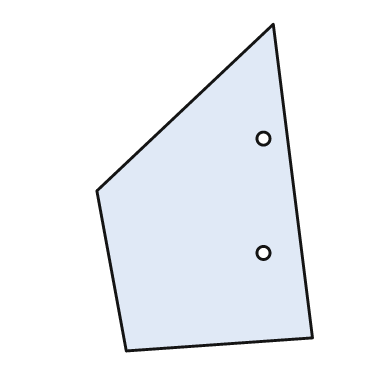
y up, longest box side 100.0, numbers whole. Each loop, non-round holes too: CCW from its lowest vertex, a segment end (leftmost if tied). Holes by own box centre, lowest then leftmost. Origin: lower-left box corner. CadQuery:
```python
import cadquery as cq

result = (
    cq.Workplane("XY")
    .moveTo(9.0, 0.0)
    .lineTo(66.0, 4.0)
    .lineTo(54.0, 100.0)
    .lineTo(0.0, 49.0)
    .close()
    .moveTo(51.0, 30.0)
    .circle(2.0)
    .moveTo(51.0, 65.0)
    .circle(2.0)
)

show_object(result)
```